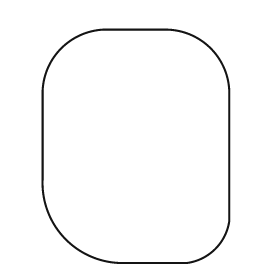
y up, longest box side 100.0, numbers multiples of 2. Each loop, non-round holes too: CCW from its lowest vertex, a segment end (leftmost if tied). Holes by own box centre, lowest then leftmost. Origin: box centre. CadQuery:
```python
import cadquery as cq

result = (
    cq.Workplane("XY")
    .moveTo(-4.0, -50.0)
    .lineTo(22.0, -50.0)
    .threePointArc((34.0, -44.0), (40.0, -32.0))
    .lineTo(40.0, 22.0)
    .threePointArc((32.0, 42.0), (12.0, 50.0))
    .lineTo(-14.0, 50.0)
    .threePointArc((-32.0, 42.0), (-40.0, 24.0))
    .lineTo(-40.0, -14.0)
    .threePointArc((-30.0, -40.0), (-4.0, -50.0))
    .close()
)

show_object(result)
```